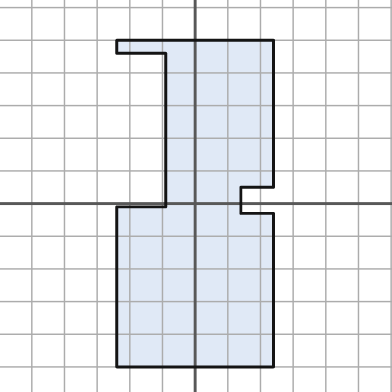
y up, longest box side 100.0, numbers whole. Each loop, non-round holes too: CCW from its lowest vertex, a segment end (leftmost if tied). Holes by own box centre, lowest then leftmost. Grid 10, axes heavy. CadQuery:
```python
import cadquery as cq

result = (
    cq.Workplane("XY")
    .moveTo(-24.0, -50.0)
    .lineTo(24.0, -50.0)
    .lineTo(24.0, -3.0)
    .lineTo(14.0, -3.0)
    .lineTo(14.0, 5.0)
    .lineTo(24.0, 5.0)
    .lineTo(24.0, 50.0)
    .lineTo(-24.0, 50.0)
    .lineTo(-24.0, 46.0)
    .lineTo(-9.0, 46.0)
    .lineTo(-9.0, -1.0)
    .lineTo(-24.0, -1.0)
    .close()
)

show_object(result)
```